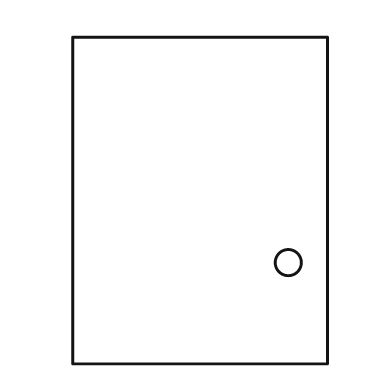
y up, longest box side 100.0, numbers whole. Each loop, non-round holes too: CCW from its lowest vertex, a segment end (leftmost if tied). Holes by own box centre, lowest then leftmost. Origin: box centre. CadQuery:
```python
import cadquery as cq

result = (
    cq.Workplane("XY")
    .moveTo(-39.0, -50.0)
    .lineTo(39.0, -50.0)
    .lineTo(39.0, 50.0)
    .lineTo(-39.0, 50.0)
    .close()
    .moveTo(27.0, -19.0)
    .circle(4.0)
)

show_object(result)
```